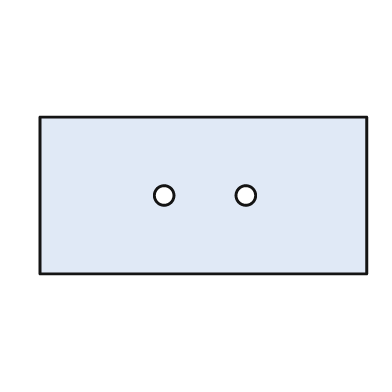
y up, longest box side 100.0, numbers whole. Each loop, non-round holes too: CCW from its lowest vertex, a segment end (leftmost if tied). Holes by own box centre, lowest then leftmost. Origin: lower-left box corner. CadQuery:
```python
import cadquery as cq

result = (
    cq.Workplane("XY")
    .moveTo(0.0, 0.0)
    .lineTo(100.0, 0.0)
    .lineTo(100.0, 48.0)
    .lineTo(0.0, 48.0)
    .close()
    .moveTo(38.0, 24.0)
    .circle(3.0)
    .moveTo(63.0, 24.0)
    .circle(3.0)
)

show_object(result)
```